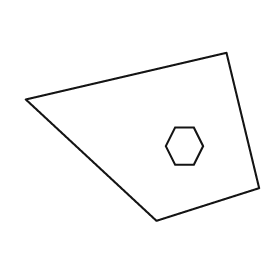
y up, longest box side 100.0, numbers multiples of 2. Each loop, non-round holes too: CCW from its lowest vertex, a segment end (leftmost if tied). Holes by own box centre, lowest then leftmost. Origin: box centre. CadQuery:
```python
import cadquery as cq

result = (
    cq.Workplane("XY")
    .moveTo(6.0, -36.0)
    .lineTo(50.0, -22.0)
    .lineTo(36.0, 36.0)
    .lineTo(-50.0, 16.0)
    .close()
    .moveTo(14.0, -12.0)
    .lineTo(22.0, -12.0)
    .lineTo(26.0, -4.0)
    .lineTo(22.0, 4.0)
    .lineTo(14.0, 4.0)
    .lineTo(10.0, -4.0)
    .close()
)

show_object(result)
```